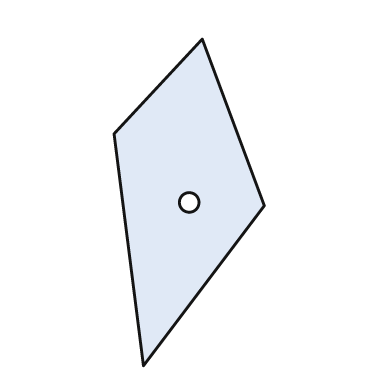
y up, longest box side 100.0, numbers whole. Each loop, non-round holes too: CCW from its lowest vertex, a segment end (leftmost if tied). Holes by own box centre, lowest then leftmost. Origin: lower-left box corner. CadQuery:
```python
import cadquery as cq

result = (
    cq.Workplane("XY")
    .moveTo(9.0, 0.0)
    .lineTo(46.0, 49.0)
    .lineTo(27.0, 100.0)
    .lineTo(0.0, 71.0)
    .close()
    .moveTo(23.0, 50.0)
    .circle(3.0)
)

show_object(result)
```